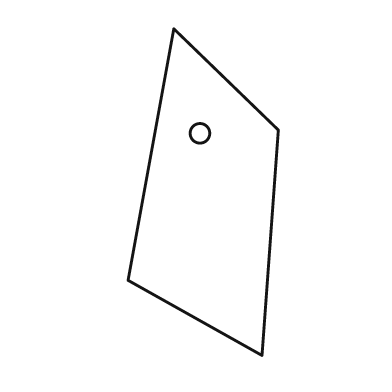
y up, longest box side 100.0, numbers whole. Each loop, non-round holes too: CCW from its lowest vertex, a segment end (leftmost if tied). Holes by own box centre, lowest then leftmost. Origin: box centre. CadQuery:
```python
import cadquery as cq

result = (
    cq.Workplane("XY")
    .moveTo(18.0, -50.0)
    .lineTo(23.0, 19.0)
    .lineTo(-9.0, 50.0)
    .lineTo(-23.0, -27.0)
    .close()
    .moveTo(-1.0, 18.0)
    .circle(3.0)
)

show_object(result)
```